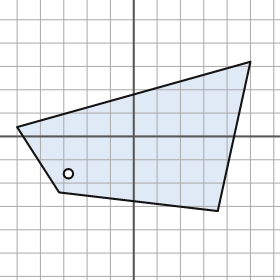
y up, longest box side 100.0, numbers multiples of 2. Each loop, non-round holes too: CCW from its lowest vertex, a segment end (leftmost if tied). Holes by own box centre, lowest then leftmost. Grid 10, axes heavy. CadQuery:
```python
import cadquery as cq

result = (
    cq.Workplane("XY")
    .moveTo(36.0, -32.0)
    .lineTo(50.0, 32.0)
    .lineTo(-50.0, 4.0)
    .lineTo(-32.0, -24.0)
    .close()
    .moveTo(-28.0, -16.0)
    .circle(2.0)
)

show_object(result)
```